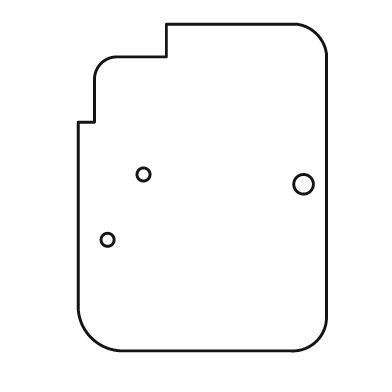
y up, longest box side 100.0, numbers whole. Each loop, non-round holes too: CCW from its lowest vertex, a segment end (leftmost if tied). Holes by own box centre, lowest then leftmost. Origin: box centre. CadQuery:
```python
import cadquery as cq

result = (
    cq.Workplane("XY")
    .moveTo(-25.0, -50.0)
    .lineTo(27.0, -50.0)
    .threePointArc((35.0, -47.0), (38.0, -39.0))
    .lineTo(38.0, 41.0)
    .threePointArc((35.0, 47.0), (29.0, 50.0))
    .lineTo(-11.0, 50.0)
    .lineTo(-11.0, 40.0)
    .lineTo(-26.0, 40.0)
    .threePointArc((-31.0, 38.0), (-33.0, 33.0))
    .lineTo(-33.0, 20.0)
    .lineTo(-38.0, 20.0)
    .lineTo(-38.0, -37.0)
    .threePointArc((-34.0, -46.0), (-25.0, -50.0))
    .close()
    .moveTo(-29.0, -16.0)
    .circle(2.0)
    .moveTo(31.0, 1.0)
    .circle(3.0)
    .moveTo(-18.0, 4.0)
    .circle(2.0)
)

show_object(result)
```